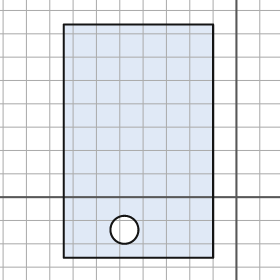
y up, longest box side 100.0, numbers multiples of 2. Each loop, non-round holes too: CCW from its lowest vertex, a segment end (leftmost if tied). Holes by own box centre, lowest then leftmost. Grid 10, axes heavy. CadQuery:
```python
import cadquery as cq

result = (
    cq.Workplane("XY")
    .moveTo(-74.0, -26.0)
    .lineTo(-10.0, -26.0)
    .lineTo(-10.0, 74.0)
    .lineTo(-74.0, 74.0)
    .close()
    .moveTo(-48.0, -14.0)
    .circle(6.0)
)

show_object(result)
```